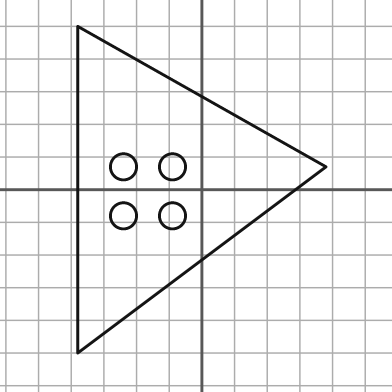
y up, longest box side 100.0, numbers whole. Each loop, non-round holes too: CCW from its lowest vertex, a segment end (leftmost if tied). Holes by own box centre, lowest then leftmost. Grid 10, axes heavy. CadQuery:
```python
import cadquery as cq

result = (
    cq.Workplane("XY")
    .moveTo(-38.0, -50.0)
    .lineTo(38.0, 7.0)
    .lineTo(-38.0, 50.0)
    .close()
    .moveTo(-24.0, -8.0)
    .circle(4.0)
    .moveTo(-9.0, -8.0)
    .circle(4.0)
    .moveTo(-24.0, 7.0)
    .circle(4.0)
    .moveTo(-9.0, 7.0)
    .circle(4.0)
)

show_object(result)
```